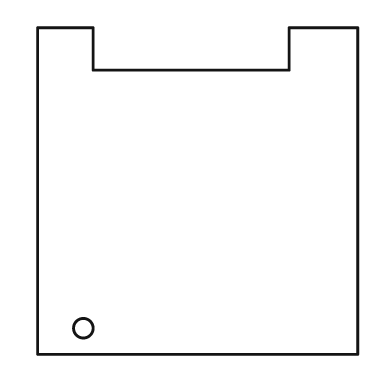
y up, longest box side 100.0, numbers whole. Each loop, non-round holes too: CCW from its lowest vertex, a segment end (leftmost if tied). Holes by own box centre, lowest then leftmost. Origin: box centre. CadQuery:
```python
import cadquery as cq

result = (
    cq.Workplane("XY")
    .moveTo(-49.0, -50.0)
    .lineTo(49.0, -50.0)
    .lineTo(49.0, 50.0)
    .lineTo(28.0, 50.0)
    .lineTo(28.0, 37.0)
    .lineTo(-32.0, 37.0)
    .lineTo(-32.0, 50.0)
    .lineTo(-49.0, 50.0)
    .close()
    .moveTo(-35.0, -42.0)
    .circle(3.0)
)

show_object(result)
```